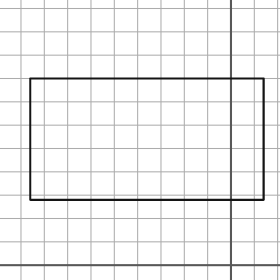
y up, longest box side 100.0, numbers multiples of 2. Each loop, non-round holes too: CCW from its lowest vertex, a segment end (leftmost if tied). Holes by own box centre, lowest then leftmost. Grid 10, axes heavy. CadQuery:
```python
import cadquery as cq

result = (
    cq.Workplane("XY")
    .moveTo(-86.0, 28.0)
    .lineTo(14.0, 28.0)
    .lineTo(14.0, 80.0)
    .lineTo(-86.0, 80.0)
    .close()
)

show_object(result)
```